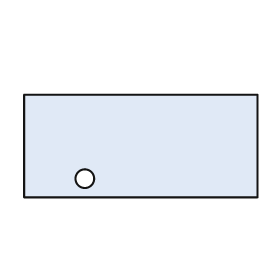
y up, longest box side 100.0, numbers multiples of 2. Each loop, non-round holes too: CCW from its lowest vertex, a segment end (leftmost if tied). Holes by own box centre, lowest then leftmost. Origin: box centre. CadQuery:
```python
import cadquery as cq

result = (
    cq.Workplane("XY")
    .moveTo(-50.0, -22.0)
    .lineTo(50.0, -22.0)
    .lineTo(50.0, 22.0)
    .lineTo(-50.0, 22.0)
    .close()
    .moveTo(-24.0, -14.0)
    .circle(4.0)
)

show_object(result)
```